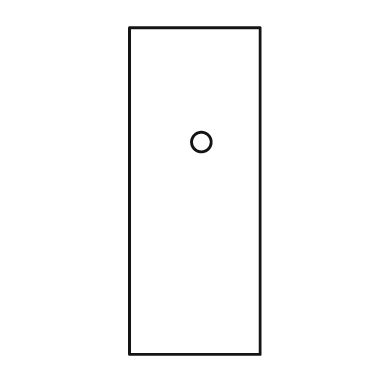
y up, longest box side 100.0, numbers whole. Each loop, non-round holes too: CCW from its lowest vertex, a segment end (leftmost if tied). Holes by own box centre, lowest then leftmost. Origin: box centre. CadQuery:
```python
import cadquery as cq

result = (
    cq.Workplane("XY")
    .moveTo(-20.0, -50.0)
    .lineTo(20.0, -50.0)
    .lineTo(20.0, 50.0)
    .lineTo(-20.0, 50.0)
    .close()
    .moveTo(2.0, 15.0)
    .circle(3.0)
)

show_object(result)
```